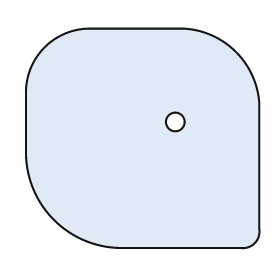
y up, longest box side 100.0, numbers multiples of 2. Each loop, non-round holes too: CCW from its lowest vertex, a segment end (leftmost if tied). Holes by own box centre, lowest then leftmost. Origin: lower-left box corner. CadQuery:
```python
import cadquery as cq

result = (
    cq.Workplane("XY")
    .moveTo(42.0, 0.0)
    .lineTo(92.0, 0.0)
    .threePointArc((98.0, 2.0), (100.0, 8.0))
    .lineTo(100.0, 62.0)
    .threePointArc((90.0, 84.0), (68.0, 94.0))
    .lineTo(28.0, 94.0)
    .threePointArc((8.0, 86.0), (0.0, 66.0))
    .lineTo(0.0, 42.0)
    .threePointArc((12.0, 12.0), (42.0, 0.0))
    .close()
    .moveTo(64.0, 54.0)
    .circle(4.0)
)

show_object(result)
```